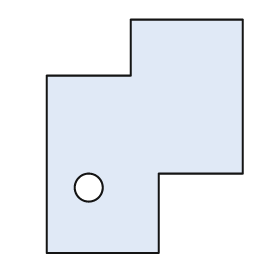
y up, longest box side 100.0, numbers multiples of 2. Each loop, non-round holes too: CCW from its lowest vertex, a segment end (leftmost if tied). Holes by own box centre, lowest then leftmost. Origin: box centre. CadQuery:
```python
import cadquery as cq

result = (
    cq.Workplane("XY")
    .moveTo(-42.0, -50.0)
    .lineTo(6.0, -50.0)
    .lineTo(6.0, -16.0)
    .lineTo(42.0, -16.0)
    .lineTo(42.0, 50.0)
    .lineTo(-6.0, 50.0)
    .lineTo(-6.0, 26.0)
    .lineTo(-42.0, 26.0)
    .close()
    .moveTo(-24.0, -22.0)
    .circle(6.0)
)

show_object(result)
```